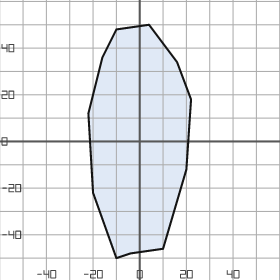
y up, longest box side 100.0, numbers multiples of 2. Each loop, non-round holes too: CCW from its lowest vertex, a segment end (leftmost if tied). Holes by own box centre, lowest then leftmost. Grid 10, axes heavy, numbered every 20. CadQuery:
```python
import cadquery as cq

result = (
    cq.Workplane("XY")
    .moveTo(-10.0, -50.0)
    .lineTo(-4.0, -48.0)
    .lineTo(10.0, -46.0)
    .lineTo(20.0, -12.0)
    .lineTo(22.0, 18.0)
    .lineTo(16.0, 34.0)
    .lineTo(4.0, 50.0)
    .lineTo(-10.0, 48.0)
    .lineTo(-16.0, 36.0)
    .lineTo(-22.0, 12.0)
    .lineTo(-20.0, -22.0)
    .close()
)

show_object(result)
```